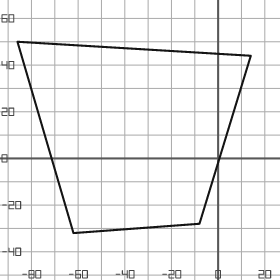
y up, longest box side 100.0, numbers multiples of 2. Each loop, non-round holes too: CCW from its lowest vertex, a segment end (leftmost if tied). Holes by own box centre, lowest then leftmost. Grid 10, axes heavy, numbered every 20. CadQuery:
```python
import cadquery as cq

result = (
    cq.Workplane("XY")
    .moveTo(-62.0, -32.0)
    .lineTo(-8.0, -28.0)
    .lineTo(14.0, 44.0)
    .lineTo(-86.0, 50.0)
    .close()
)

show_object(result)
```